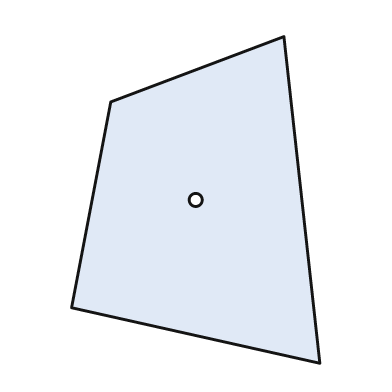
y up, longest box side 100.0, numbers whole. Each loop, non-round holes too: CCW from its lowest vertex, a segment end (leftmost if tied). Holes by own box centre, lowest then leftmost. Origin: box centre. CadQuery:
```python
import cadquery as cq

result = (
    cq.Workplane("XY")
    .moveTo(38.0, -50.0)
    .lineTo(27.0, 50.0)
    .lineTo(-26.0, 30.0)
    .lineTo(-38.0, -33.0)
    .close()
    .moveTo(0.0, 0.0)
    .circle(2.0)
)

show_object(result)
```